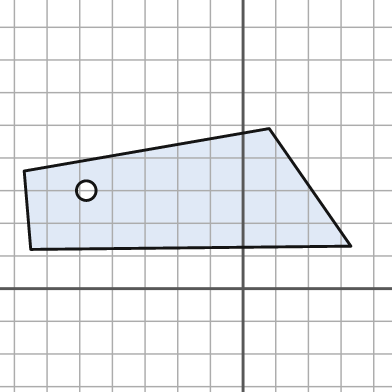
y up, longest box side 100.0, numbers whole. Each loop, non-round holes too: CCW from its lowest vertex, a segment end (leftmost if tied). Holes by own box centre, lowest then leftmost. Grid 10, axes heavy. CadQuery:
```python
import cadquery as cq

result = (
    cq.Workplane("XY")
    .moveTo(-65.0, 12.0)
    .lineTo(33.0, 13.0)
    .lineTo(8.0, 49.0)
    .lineTo(-67.0, 36.0)
    .close()
    .moveTo(-48.0, 30.0)
    .circle(3.0)
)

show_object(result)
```